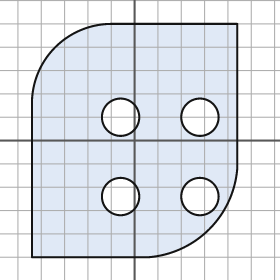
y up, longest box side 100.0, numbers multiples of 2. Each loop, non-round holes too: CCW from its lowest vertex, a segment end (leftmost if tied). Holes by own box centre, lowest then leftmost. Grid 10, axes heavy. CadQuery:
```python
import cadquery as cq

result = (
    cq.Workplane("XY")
    .moveTo(-44.0, -50.0)
    .lineTo(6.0, -50.0)
    .threePointArc((32.0, -38.0), (44.0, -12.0))
    .lineTo(44.0, 50.0)
    .lineTo(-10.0, 50.0)
    .threePointArc((-34.0, 40.0), (-44.0, 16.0))
    .close()
    .moveTo(-6.0, -24.0)
    .circle(8.0)
    .moveTo(28.0, -24.0)
    .circle(8.0)
    .moveTo(-6.0, 10.0)
    .circle(8.0)
    .moveTo(28.0, 10.0)
    .circle(8.0)
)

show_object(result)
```